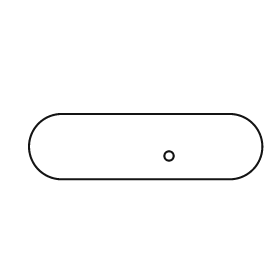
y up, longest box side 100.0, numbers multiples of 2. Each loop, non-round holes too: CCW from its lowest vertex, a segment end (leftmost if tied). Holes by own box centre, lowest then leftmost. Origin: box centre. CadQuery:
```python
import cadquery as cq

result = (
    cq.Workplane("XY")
    .moveTo(-36.0, -14.0)
    .lineTo(36.0, -14.0)
    .threePointArc((50.0, 0.0), (36.0, 14.0))
    .lineTo(-36.0, 14.0)
    .threePointArc((-50.0, 0.0), (-36.0, -14.0))
    .close()
    .moveTo(10.0, -4.0)
    .circle(2.0)
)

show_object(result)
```